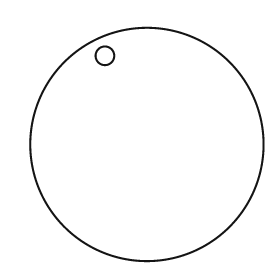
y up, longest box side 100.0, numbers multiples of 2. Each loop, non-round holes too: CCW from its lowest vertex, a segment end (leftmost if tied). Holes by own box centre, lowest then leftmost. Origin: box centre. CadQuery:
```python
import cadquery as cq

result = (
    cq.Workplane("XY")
    .moveTo(0.0, 0.0)
    .circle(50.0)
    .moveTo(-18.0, 38.0)
    .circle(4.0)
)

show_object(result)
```